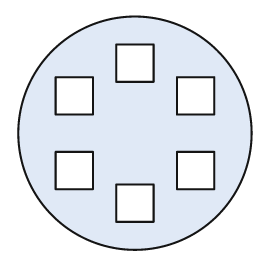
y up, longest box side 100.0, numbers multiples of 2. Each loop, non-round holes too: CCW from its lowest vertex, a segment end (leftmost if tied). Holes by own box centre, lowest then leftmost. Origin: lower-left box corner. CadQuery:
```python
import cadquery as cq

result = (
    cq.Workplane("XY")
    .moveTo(50.0, 50.0)
    .circle(50.0)
    .moveTo(42.0, 12.0)
    .lineTo(58.0, 12.0)
    .lineTo(58.0, 28.0)
    .lineTo(42.0, 28.0)
    .close()
    .moveTo(16.0, 26.0)
    .lineTo(32.0, 26.0)
    .lineTo(32.0, 42.0)
    .lineTo(16.0, 42.0)
    .close()
    .moveTo(68.0, 26.0)
    .lineTo(84.0, 26.0)
    .lineTo(84.0, 42.0)
    .lineTo(68.0, 42.0)
    .close()
    .moveTo(16.0, 58.0)
    .lineTo(32.0, 58.0)
    .lineTo(32.0, 74.0)
    .lineTo(16.0, 74.0)
    .close()
    .moveTo(68.0, 58.0)
    .lineTo(84.0, 58.0)
    .lineTo(84.0, 74.0)
    .lineTo(68.0, 74.0)
    .close()
    .moveTo(42.0, 72.0)
    .lineTo(58.0, 72.0)
    .lineTo(58.0, 88.0)
    .lineTo(42.0, 88.0)
    .close()
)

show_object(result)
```